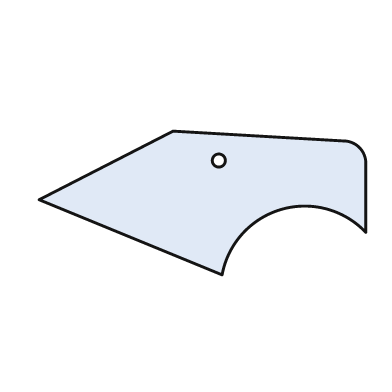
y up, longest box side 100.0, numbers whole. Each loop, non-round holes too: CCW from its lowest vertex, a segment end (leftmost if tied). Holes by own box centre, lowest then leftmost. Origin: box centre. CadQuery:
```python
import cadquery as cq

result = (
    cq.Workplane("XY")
    .moveTo(6.0, -22.0)
    .threePointArc((24.0, -2.0), (50.0, -9.0))
    .lineTo(50.0, 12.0)
    .threePointArc((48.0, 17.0), (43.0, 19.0))
    .lineTo(-9.0, 22.0)
    .lineTo(-50.0, 1.0)
    .close()
    .moveTo(5.0, 13.0)
    .circle(2.0)
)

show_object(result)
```